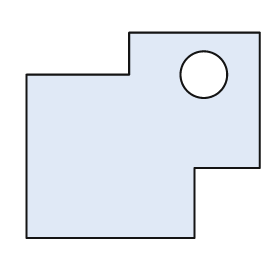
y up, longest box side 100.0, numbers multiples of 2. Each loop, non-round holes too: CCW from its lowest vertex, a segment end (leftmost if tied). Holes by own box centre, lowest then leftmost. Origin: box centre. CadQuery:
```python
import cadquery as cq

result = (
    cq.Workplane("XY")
    .moveTo(-50.0, -44.0)
    .lineTo(22.0, -44.0)
    .lineTo(22.0, -14.0)
    .lineTo(50.0, -14.0)
    .lineTo(50.0, 44.0)
    .lineTo(-6.0, 44.0)
    .lineTo(-6.0, 26.0)
    .lineTo(-50.0, 26.0)
    .close()
    .moveTo(26.0, 26.0)
    .circle(10.0)
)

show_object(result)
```